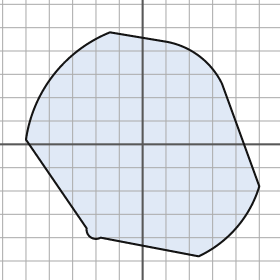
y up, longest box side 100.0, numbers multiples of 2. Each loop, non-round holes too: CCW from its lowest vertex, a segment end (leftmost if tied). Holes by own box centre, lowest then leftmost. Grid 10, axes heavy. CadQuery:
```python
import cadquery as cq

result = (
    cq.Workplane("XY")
    .moveTo(24.0, -48.0)
    .threePointArc((40.0, -36.0), (50.0, -18.0))
    .lineTo(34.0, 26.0)
    .threePointArc((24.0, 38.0), (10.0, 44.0))
    .lineTo(-14.0, 48.0)
    .threePointArc((-38.0, 30.0), (-50.0, 2.0))
    .lineTo(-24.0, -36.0)
    .threePointArc((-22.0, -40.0), (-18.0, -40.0))
    .close()
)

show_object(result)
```